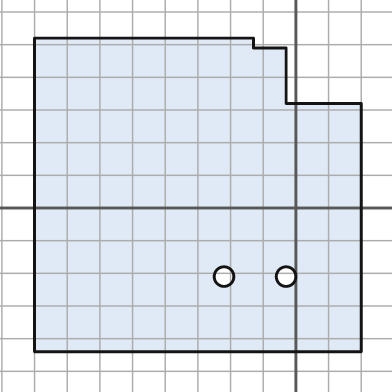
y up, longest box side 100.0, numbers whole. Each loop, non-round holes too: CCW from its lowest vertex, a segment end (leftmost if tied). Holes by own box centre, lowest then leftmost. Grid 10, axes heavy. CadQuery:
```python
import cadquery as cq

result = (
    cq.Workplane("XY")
    .moveTo(-80.0, -44.0)
    .lineTo(20.0, -44.0)
    .lineTo(20.0, 32.0)
    .lineTo(-3.0, 32.0)
    .lineTo(-3.0, 49.0)
    .lineTo(-13.0, 49.0)
    .lineTo(-13.0, 52.0)
    .lineTo(-80.0, 52.0)
    .close()
    .moveTo(-22.0, -21.0)
    .circle(3.0)
    .moveTo(-3.0, -21.0)
    .circle(3.0)
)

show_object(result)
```